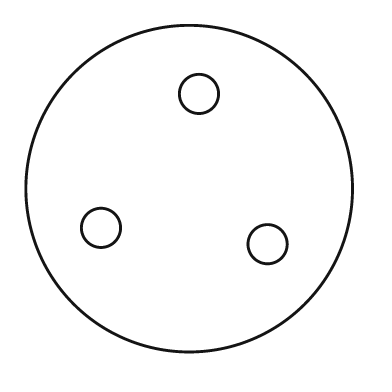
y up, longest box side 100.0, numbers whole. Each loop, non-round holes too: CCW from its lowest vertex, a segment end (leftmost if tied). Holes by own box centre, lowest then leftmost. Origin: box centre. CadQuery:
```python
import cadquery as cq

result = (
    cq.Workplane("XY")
    .moveTo(0.0, 0.0)
    .circle(50.0)
    .moveTo(24.0, -17.0)
    .circle(6.0)
    .moveTo(-27.0, -12.0)
    .circle(6.0)
    .moveTo(3.0, 29.0)
    .circle(6.0)
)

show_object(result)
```